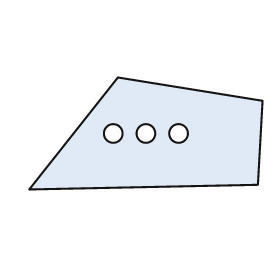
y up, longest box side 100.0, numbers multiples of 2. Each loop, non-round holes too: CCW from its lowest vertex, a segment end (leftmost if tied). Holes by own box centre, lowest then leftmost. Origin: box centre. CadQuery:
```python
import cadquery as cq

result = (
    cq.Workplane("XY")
    .moveTo(-50.0, -24.0)
    .lineTo(48.0, -22.0)
    .lineTo(50.0, 14.0)
    .lineTo(-12.0, 24.0)
    .close()
    .moveTo(-14.0, 0.0)
    .circle(4.0)
    .moveTo(0.0, 0.0)
    .circle(4.0)
    .moveTo(14.0, 0.0)
    .circle(4.0)
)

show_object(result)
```